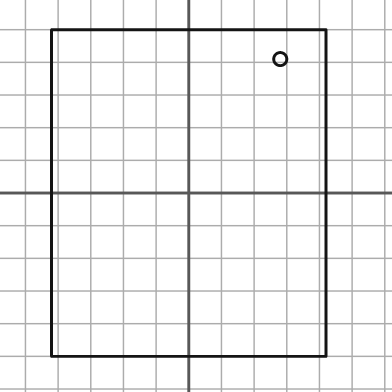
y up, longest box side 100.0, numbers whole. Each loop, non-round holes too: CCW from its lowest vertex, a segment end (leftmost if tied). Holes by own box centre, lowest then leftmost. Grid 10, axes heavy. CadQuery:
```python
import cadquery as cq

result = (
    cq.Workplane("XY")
    .moveTo(-42.0, -50.0)
    .lineTo(42.0, -50.0)
    .lineTo(42.0, 50.0)
    .lineTo(-42.0, 50.0)
    .close()
    .moveTo(28.0, 41.0)
    .circle(2.0)
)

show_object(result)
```